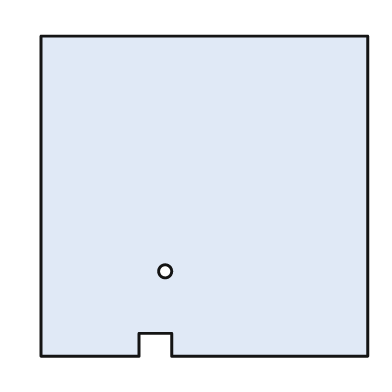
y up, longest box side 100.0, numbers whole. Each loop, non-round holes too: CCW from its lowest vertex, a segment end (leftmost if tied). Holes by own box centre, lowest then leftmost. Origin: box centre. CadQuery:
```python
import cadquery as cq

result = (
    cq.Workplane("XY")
    .moveTo(-50.0, -49.0)
    .lineTo(-20.0, -49.0)
    .lineTo(-20.0, -42.0)
    .lineTo(-10.0, -42.0)
    .lineTo(-10.0, -49.0)
    .lineTo(50.0, -49.0)
    .lineTo(50.0, 49.0)
    .lineTo(-50.0, 49.0)
    .close()
    .moveTo(-12.0, -23.0)
    .circle(2.0)
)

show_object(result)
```